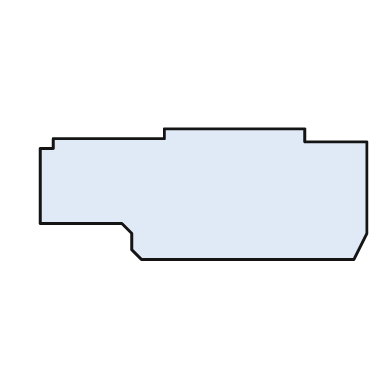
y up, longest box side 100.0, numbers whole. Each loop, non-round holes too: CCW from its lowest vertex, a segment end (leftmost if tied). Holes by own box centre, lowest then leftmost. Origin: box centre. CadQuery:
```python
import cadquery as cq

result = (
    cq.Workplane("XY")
    .moveTo(-19.0, -20.0)
    .lineTo(46.0, -20.0)
    .lineTo(50.0, -12.0)
    .lineTo(50.0, 16.0)
    .lineTo(31.0, 16.0)
    .lineTo(31.0, 20.0)
    .lineTo(-12.0, 20.0)
    .lineTo(-12.0, 17.0)
    .lineTo(-46.0, 17.0)
    .lineTo(-46.0, 14.0)
    .lineTo(-50.0, 14.0)
    .lineTo(-50.0, -9.0)
    .lineTo(-25.0, -9.0)
    .lineTo(-22.0, -12.0)
    .lineTo(-22.0, -17.0)
    .close()
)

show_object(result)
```